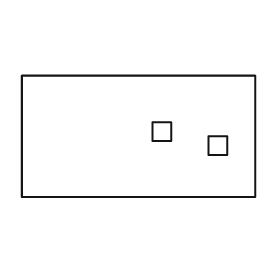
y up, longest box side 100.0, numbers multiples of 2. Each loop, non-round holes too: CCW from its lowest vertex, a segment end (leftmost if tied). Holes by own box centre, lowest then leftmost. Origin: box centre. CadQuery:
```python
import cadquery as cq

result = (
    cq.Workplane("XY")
    .moveTo(-50.0, -26.0)
    .lineTo(50.0, -26.0)
    .lineTo(50.0, 26.0)
    .lineTo(-50.0, 26.0)
    .close()
    .moveTo(30.0, -8.0)
    .lineTo(38.0, -8.0)
    .lineTo(38.0, 0.0)
    .lineTo(30.0, 0.0)
    .close()
    .moveTo(6.0, -2.0)
    .lineTo(14.0, -2.0)
    .lineTo(14.0, 6.0)
    .lineTo(6.0, 6.0)
    .close()
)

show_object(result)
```